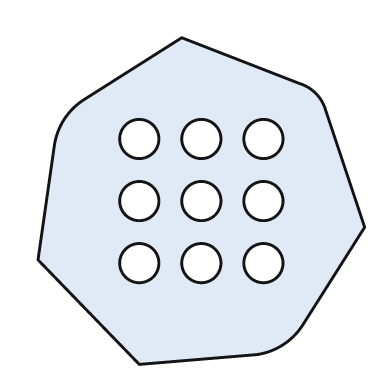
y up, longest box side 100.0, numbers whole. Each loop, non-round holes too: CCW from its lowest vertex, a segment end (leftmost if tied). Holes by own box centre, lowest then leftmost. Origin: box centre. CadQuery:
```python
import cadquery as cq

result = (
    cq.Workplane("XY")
    .moveTo(-19.0, -50.0)
    .lineTo(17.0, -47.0)
    .threePointArc((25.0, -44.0), (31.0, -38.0))
    .lineTo(50.0, -8.0)
    .lineTo(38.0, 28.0)
    .threePointArc((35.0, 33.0), (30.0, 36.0))
    .lineTo(-6.0, 50.0)
    .lineTo(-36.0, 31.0)
    .threePointArc((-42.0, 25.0), (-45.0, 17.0))
    .lineTo(-50.0, -18.0)
    .close()
    .moveTo(-19.0, -19.0)
    .circle(6.0)
    .moveTo(0.0, -19.0)
    .circle(6.0)
    .moveTo(19.0, -19.0)
    .circle(6.0)
    .moveTo(-19.0, 0.0)
    .circle(6.0)
    .moveTo(0.0, 0.0)
    .circle(6.0)
    .moveTo(19.0, 0.0)
    .circle(6.0)
    .moveTo(-19.0, 19.0)
    .circle(6.0)
    .moveTo(0.0, 19.0)
    .circle(6.0)
    .moveTo(19.0, 19.0)
    .circle(6.0)
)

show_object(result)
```